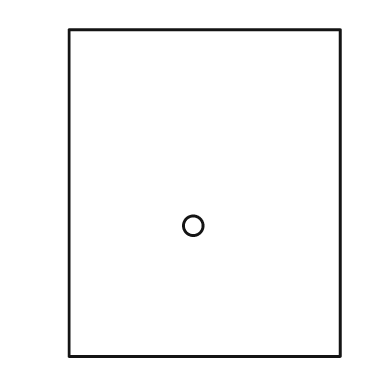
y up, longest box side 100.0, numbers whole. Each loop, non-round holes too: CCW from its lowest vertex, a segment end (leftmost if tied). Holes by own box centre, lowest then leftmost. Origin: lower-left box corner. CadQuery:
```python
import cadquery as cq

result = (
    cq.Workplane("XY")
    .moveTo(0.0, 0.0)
    .lineTo(83.0, 0.0)
    .lineTo(83.0, 100.0)
    .lineTo(0.0, 100.0)
    .close()
    .moveTo(38.0, 40.0)
    .circle(3.0)
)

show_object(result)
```